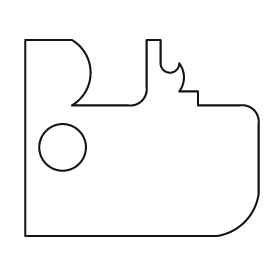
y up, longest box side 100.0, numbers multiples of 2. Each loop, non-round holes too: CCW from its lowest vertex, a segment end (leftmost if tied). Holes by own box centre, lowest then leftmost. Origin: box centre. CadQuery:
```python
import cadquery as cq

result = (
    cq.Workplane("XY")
    .moveTo(-50.0, -42.0)
    .lineTo(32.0, -42.0)
    .threePointArc((44.0, -36.0), (50.0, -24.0))
    .lineTo(50.0, 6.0)
    .threePointArc((48.0, 12.0), (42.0, 14.0))
    .lineTo(24.0, 14.0)
    .lineTo(24.0, 20.0)
    .lineTo(16.0, 20.0)
    .threePointArc((18.0, 26.0), (16.0, 32.0))
    .threePointArc((12.0, 28.0), (8.0, 32.0))
    .lineTo(8.0, 42.0)
    .lineTo(2.0, 42.0)
    .lineTo(2.0, 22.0)
    .threePointArc((0.0, 16.0), (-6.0, 14.0))
    .lineTo(-30.0, 14.0)
    .threePointArc((-22.0, 28.0), (-30.0, 42.0))
    .lineTo(-50.0, 42.0)
    .close()
    .moveTo(-34.0, -4.0)
    .circle(10.0)
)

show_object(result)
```